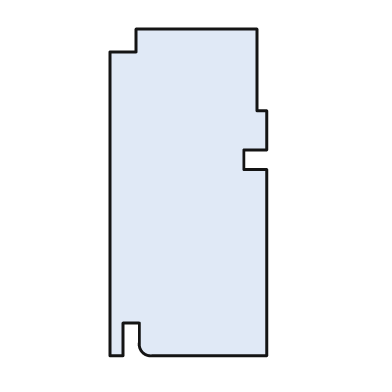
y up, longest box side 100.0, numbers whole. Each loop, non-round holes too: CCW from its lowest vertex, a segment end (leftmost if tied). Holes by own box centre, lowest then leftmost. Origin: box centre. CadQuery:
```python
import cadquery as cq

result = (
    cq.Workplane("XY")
    .moveTo(-24.0, -50.0)
    .lineTo(-20.0, -50.0)
    .lineTo(-20.0, -40.0)
    .lineTo(-15.0, -40.0)
    .lineTo(-15.0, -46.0)
    .threePointArc((-14.0, -49.0), (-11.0, -50.0))
    .lineTo(24.0, -50.0)
    .lineTo(24.0, 7.0)
    .lineTo(17.0, 7.0)
    .lineTo(17.0, 13.0)
    .lineTo(24.0, 13.0)
    .lineTo(24.0, 25.0)
    .lineTo(21.0, 25.0)
    .lineTo(21.0, 50.0)
    .lineTo(-16.0, 50.0)
    .lineTo(-16.0, 43.0)
    .lineTo(-24.0, 43.0)
    .close()
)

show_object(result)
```